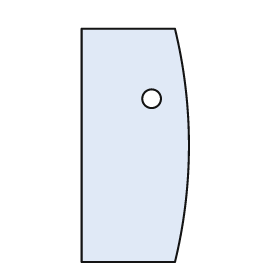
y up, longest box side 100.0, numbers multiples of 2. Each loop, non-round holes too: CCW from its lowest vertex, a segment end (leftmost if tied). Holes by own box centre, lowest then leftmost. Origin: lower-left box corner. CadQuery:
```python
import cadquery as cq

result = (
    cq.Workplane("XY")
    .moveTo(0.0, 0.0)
    .lineTo(40.0, 0.0)
    .threePointArc((46.0, 50.0), (40.0, 100.0))
    .lineTo(0.0, 100.0)
    .close()
    .moveTo(30.0, 70.0)
    .circle(4.0)
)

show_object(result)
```